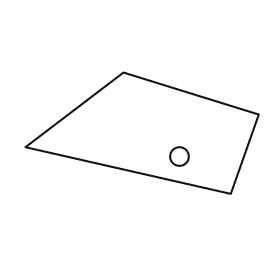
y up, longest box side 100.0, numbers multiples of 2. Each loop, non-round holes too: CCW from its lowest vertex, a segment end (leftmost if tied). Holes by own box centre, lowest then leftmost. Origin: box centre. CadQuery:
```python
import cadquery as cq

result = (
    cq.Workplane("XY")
    .moveTo(38.0, -26.0)
    .lineTo(50.0, 8.0)
    .lineTo(-8.0, 26.0)
    .lineTo(-50.0, -6.0)
    .close()
    .moveTo(16.0, -10.0)
    .circle(4.0)
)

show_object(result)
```